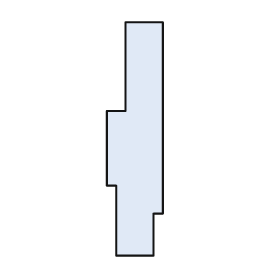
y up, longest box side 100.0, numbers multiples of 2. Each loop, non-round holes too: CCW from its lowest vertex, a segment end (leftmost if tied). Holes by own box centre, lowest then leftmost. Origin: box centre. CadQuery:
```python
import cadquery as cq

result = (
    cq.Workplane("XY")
    .moveTo(-8.0, -50.0)
    .lineTo(8.0, -50.0)
    .lineTo(8.0, -32.0)
    .lineTo(12.0, -32.0)
    .lineTo(12.0, 50.0)
    .lineTo(-4.0, 50.0)
    .lineTo(-4.0, 12.0)
    .lineTo(-12.0, 12.0)
    .lineTo(-12.0, -20.0)
    .lineTo(-8.0, -20.0)
    .close()
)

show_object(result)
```